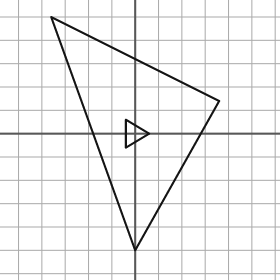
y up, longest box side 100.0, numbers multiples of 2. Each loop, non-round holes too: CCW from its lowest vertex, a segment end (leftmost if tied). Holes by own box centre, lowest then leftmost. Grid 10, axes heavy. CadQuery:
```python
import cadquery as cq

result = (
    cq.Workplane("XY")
    .moveTo(0.0, -50.0)
    .lineTo(36.0, 14.0)
    .lineTo(-36.0, 50.0)
    .close()
    .moveTo(-4.0, -6.0)
    .lineTo(6.0, 0.0)
    .lineTo(-4.0, 6.0)
    .close()
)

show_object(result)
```